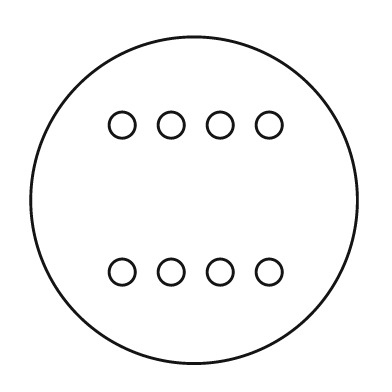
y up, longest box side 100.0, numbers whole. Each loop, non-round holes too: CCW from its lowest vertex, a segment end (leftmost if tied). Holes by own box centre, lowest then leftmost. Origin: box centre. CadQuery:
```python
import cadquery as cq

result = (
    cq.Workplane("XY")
    .moveTo(0.0, 0.0)
    .circle(50.0)
    .moveTo(-22.0, -22.0)
    .circle(4.0)
    .moveTo(-7.0, -22.0)
    .circle(4.0)
    .moveTo(8.0, -22.0)
    .circle(4.0)
    .moveTo(23.0, -22.0)
    .circle(4.0)
    .moveTo(-22.0, 23.0)
    .circle(4.0)
    .moveTo(-7.0, 23.0)
    .circle(4.0)
    .moveTo(8.0, 23.0)
    .circle(4.0)
    .moveTo(23.0, 23.0)
    .circle(4.0)
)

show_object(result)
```